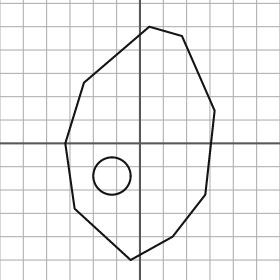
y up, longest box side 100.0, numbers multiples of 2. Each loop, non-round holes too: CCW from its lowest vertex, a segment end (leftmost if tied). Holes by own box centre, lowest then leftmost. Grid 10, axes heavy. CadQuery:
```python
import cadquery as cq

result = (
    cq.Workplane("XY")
    .moveTo(-4.0, -50.0)
    .lineTo(14.0, -40.0)
    .lineTo(28.0, -22.0)
    .lineTo(32.0, 14.0)
    .lineTo(18.0, 46.0)
    .lineTo(4.0, 50.0)
    .lineTo(-24.0, 26.0)
    .lineTo(-32.0, 0.0)
    .lineTo(-28.0, -28.0)
    .close()
    .moveTo(-12.0, -14.0)
    .circle(8.0)
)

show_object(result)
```